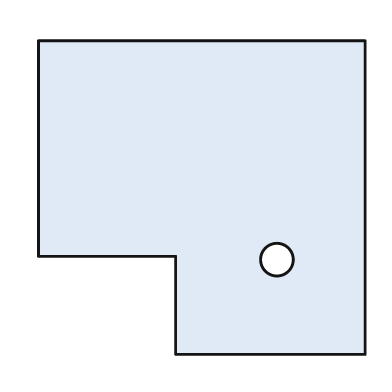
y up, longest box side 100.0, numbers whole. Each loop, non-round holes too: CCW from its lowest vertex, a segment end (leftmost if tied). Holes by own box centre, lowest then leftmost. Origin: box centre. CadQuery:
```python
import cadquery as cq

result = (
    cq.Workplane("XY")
    .moveTo(-8.0, -48.0)
    .lineTo(50.0, -48.0)
    .lineTo(50.0, 48.0)
    .lineTo(-50.0, 48.0)
    .lineTo(-50.0, -18.0)
    .lineTo(-8.0, -18.0)
    .close()
    .moveTo(23.0, -19.0)
    .circle(5.0)
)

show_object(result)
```